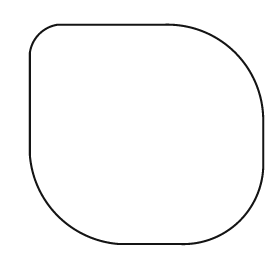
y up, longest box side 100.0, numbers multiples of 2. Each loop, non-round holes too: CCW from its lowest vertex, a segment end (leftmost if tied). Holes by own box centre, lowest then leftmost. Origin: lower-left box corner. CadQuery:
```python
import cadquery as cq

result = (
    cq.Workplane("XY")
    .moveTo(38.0, 0.0)
    .lineTo(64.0, 0.0)
    .threePointArc((90.0, 10.0), (100.0, 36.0))
    .lineTo(100.0, 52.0)
    .threePointArc((88.0, 82.0), (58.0, 94.0))
    .lineTo(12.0, 94.0)
    .threePointArc((4.0, 90.0), (0.0, 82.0))
    .lineTo(0.0, 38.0)
    .threePointArc((12.0, 12.0), (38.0, 0.0))
    .close()
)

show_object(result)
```